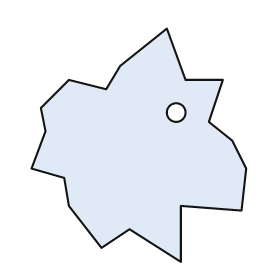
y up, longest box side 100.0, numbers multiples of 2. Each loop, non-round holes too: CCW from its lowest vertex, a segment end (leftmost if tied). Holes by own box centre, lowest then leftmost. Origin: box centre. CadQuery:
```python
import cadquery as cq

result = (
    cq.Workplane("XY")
    .moveTo(18.0, -50.0)
    .lineTo(18.0, -26.0)
    .lineTo(44.0, -28.0)
    .lineTo(46.0, -10.0)
    .lineTo(40.0, 2.0)
    .lineTo(30.0, 10.0)
    .lineTo(36.0, 28.0)
    .lineTo(20.0, 28.0)
    .lineTo(12.0, 50.0)
    .lineTo(-8.0, 34.0)
    .lineTo(-14.0, 24.0)
    .lineTo(-30.0, 28.0)
    .lineTo(-42.0, 16.0)
    .lineTo(-40.0, 6.0)
    .lineTo(-46.0, -10.0)
    .lineTo(-32.0, -14.0)
    .lineTo(-30.0, -26.0)
    .lineTo(-16.0, -44.0)
    .lineTo(-4.0, -36.0)
    .close()
    .moveTo(16.0, 14.0)
    .circle(4.0)
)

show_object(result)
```